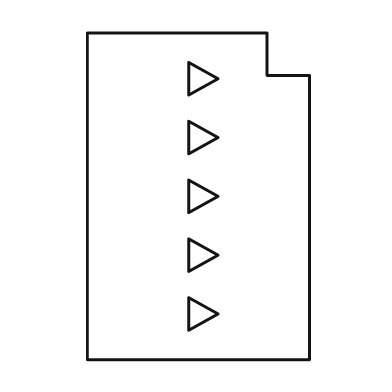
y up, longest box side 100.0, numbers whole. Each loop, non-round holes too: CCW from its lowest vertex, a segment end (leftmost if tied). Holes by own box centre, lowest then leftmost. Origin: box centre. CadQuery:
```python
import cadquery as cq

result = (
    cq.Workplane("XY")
    .moveTo(-34.0, -50.0)
    .lineTo(34.0, -50.0)
    .lineTo(34.0, 37.0)
    .lineTo(21.0, 37.0)
    .lineTo(21.0, 50.0)
    .lineTo(-34.0, 50.0)
    .close()
    .moveTo(-3.0, -41.0)
    .lineTo(6.0, -36.0)
    .lineTo(-3.0, -31.0)
    .close()
    .moveTo(-3.0, -23.0)
    .lineTo(6.0, -18.0)
    .lineTo(-3.0, -13.0)
    .close()
    .moveTo(-3.0, -5.0)
    .lineTo(6.0, 0.0)
    .lineTo(-3.0, 5.0)
    .close()
    .moveTo(-3.0, 13.0)
    .lineTo(6.0, 18.0)
    .lineTo(-3.0, 23.0)
    .close()
    .moveTo(-3.0, 31.0)
    .lineTo(6.0, 36.0)
    .lineTo(-3.0, 41.0)
    .close()
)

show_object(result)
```